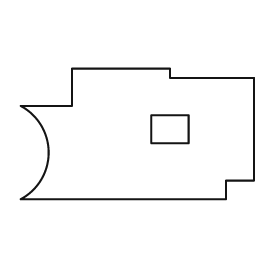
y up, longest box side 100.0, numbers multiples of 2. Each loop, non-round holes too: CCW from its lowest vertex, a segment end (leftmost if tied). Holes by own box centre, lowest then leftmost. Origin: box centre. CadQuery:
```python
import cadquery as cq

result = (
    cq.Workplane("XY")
    .moveTo(-50.0, -28.0)
    .lineTo(38.0, -28.0)
    .lineTo(38.0, -20.0)
    .lineTo(50.0, -20.0)
    .lineTo(50.0, 24.0)
    .lineTo(14.0, 24.0)
    .lineTo(14.0, 28.0)
    .lineTo(-28.0, 28.0)
    .lineTo(-28.0, 12.0)
    .lineTo(-50.0, 12.0)
    .threePointArc((-38.0, -8.0), (-50.0, -28.0))
    .close()
    .moveTo(6.0, -4.0)
    .lineTo(22.0, -4.0)
    .lineTo(22.0, 8.0)
    .lineTo(6.0, 8.0)
    .close()
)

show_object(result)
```